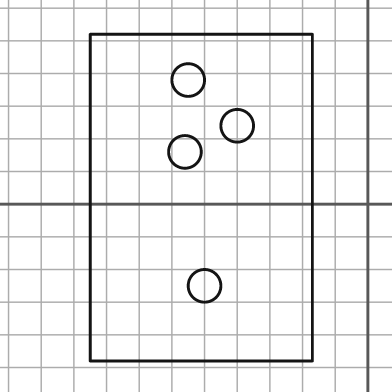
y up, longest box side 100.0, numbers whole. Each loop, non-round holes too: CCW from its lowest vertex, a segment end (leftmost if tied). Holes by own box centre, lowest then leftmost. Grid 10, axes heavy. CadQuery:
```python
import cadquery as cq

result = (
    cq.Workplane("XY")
    .moveTo(-85.0, -48.0)
    .lineTo(-17.0, -48.0)
    .lineTo(-17.0, 52.0)
    .lineTo(-85.0, 52.0)
    .close()
    .moveTo(-50.0, -25.0)
    .circle(5.0)
    .moveTo(-56.0, 16.0)
    .circle(5.0)
    .moveTo(-40.0, 24.0)
    .circle(5.0)
    .moveTo(-55.0, 38.0)
    .circle(5.0)
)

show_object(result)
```